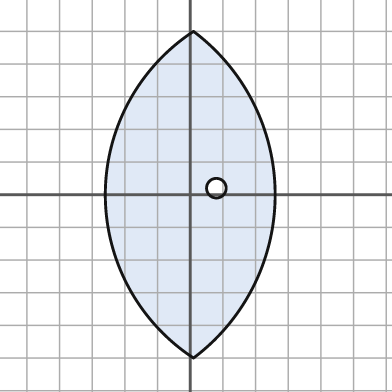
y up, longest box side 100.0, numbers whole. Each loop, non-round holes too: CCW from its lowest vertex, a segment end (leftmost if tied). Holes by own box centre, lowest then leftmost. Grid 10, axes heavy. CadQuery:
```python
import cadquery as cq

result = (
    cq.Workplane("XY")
    .moveTo(1.0, -50.0)
    .threePointArc((26.0, 0.0), (1.0, 50.0))
    .threePointArc((-26.0, 0.0), (1.0, -50.0))
    .close()
    .moveTo(8.0, 2.0)
    .circle(3.0)
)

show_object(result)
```